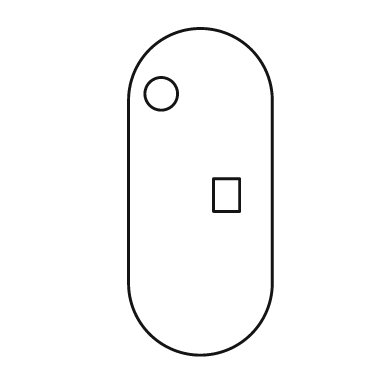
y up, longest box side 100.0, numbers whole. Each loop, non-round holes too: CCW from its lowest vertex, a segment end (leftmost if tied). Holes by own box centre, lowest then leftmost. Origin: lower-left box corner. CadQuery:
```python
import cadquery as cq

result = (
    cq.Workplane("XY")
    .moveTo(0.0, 22.0)
    .threePointArc((22.0, 0.0), (44.0, 22.0))
    .lineTo(44.0, 78.0)
    .threePointArc((22.0, 100.0), (0.0, 78.0))
    .close()
    .moveTo(26.0, 44.0)
    .lineTo(34.0, 44.0)
    .lineTo(34.0, 54.0)
    .lineTo(26.0, 54.0)
    .close()
    .moveTo(10.0, 80.0)
    .circle(5.0)
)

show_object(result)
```